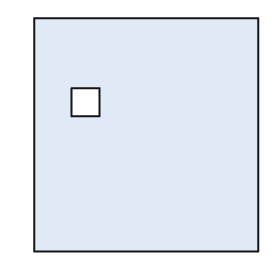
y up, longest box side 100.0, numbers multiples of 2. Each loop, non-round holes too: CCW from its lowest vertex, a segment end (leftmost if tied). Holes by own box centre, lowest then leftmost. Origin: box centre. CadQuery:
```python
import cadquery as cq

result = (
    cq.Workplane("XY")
    .moveTo(-48.0, -50.0)
    .lineTo(48.0, -50.0)
    .lineTo(48.0, 50.0)
    .lineTo(-48.0, 50.0)
    .close()
    .moveTo(-32.0, 8.0)
    .lineTo(-20.0, 8.0)
    .lineTo(-20.0, 20.0)
    .lineTo(-32.0, 20.0)
    .close()
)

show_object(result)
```